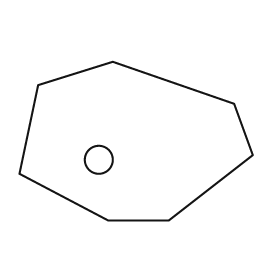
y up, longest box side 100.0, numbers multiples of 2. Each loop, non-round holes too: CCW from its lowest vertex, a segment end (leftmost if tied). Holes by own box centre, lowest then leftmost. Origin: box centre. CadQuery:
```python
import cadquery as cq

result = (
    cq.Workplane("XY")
    .moveTo(-12.0, -34.0)
    .lineTo(14.0, -34.0)
    .lineTo(50.0, -6.0)
    .lineTo(42.0, 16.0)
    .lineTo(-10.0, 34.0)
    .lineTo(-42.0, 24.0)
    .lineTo(-50.0, -14.0)
    .close()
    .moveTo(-16.0, -8.0)
    .circle(6.0)
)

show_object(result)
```